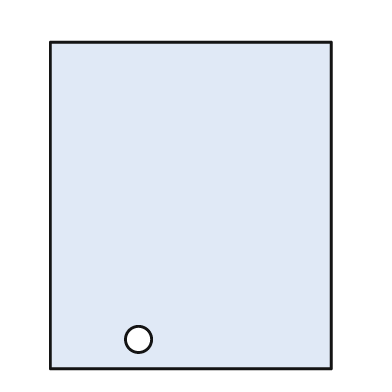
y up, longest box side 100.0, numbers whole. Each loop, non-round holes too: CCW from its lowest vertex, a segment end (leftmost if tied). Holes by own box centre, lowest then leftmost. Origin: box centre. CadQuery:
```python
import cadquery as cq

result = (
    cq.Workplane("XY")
    .moveTo(-43.0, -50.0)
    .lineTo(43.0, -50.0)
    .lineTo(43.0, 50.0)
    .lineTo(-43.0, 50.0)
    .close()
    .moveTo(-16.0, -41.0)
    .circle(4.0)
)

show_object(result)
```